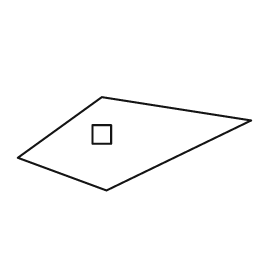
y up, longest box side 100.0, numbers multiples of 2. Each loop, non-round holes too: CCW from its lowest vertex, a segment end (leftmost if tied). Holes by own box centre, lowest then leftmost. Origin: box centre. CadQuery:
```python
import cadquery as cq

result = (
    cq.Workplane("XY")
    .moveTo(-12.0, -20.0)
    .lineTo(50.0, 10.0)
    .lineTo(-14.0, 20.0)
    .lineTo(-50.0, -6.0)
    .close()
    .moveTo(-18.0, 0.0)
    .lineTo(-10.0, 0.0)
    .lineTo(-10.0, 8.0)
    .lineTo(-18.0, 8.0)
    .close()
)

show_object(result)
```